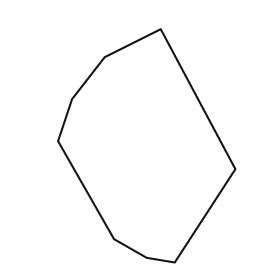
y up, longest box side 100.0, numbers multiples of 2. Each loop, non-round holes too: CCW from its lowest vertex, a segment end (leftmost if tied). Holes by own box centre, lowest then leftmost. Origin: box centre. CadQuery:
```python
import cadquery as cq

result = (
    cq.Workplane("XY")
    .moveTo(12.0, -50.0)
    .lineTo(38.0, -10.0)
    .lineTo(6.0, 50.0)
    .lineTo(-18.0, 38.0)
    .lineTo(-32.0, 20.0)
    .lineTo(-38.0, 2.0)
    .lineTo(-14.0, -40.0)
    .lineTo(0.0, -48.0)
    .close()
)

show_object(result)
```